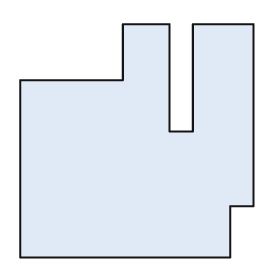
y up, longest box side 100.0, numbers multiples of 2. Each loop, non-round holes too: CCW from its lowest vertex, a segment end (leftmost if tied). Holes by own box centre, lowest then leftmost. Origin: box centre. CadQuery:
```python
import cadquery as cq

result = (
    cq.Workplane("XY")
    .moveTo(-50.0, -50.0)
    .lineTo(40.0, -50.0)
    .lineTo(40.0, -28.0)
    .lineTo(50.0, -28.0)
    .lineTo(50.0, 50.0)
    .lineTo(24.0, 50.0)
    .lineTo(24.0, 4.0)
    .lineTo(14.0, 4.0)
    .lineTo(14.0, 50.0)
    .lineTo(-6.0, 50.0)
    .lineTo(-6.0, 26.0)
    .lineTo(-50.0, 26.0)
    .close()
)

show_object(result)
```